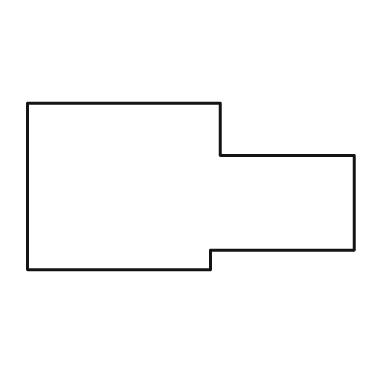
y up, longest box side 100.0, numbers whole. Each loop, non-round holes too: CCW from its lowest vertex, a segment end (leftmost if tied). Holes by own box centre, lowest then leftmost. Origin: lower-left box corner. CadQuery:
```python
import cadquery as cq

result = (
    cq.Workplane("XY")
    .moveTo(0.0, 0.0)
    .lineTo(56.0, 0.0)
    .lineTo(56.0, 6.0)
    .lineTo(100.0, 6.0)
    .lineTo(100.0, 35.0)
    .lineTo(59.0, 35.0)
    .lineTo(59.0, 51.0)
    .lineTo(0.0, 51.0)
    .close()
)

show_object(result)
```